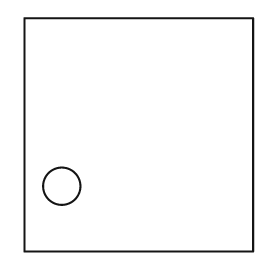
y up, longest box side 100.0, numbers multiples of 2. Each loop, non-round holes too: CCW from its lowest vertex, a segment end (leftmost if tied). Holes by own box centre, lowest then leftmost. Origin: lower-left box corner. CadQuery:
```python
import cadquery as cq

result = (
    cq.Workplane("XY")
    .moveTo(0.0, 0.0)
    .lineTo(98.0, 0.0)
    .lineTo(98.0, 100.0)
    .lineTo(0.0, 100.0)
    .close()
    .moveTo(16.0, 28.0)
    .circle(8.0)
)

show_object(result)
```